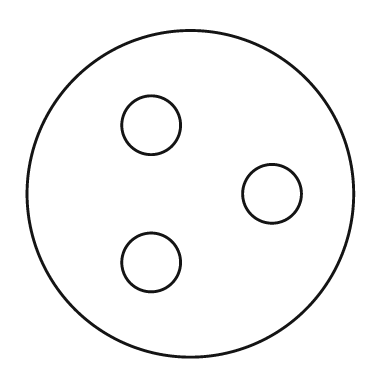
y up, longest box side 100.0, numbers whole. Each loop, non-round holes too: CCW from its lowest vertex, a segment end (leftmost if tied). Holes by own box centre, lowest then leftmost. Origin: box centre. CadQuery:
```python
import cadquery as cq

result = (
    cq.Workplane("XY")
    .moveTo(0.0, 0.0)
    .circle(50.0)
    .moveTo(-12.0, -21.0)
    .circle(9.0)
    .moveTo(25.0, 0.0)
    .circle(9.0)
    .moveTo(-12.0, 21.0)
    .circle(9.0)
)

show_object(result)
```